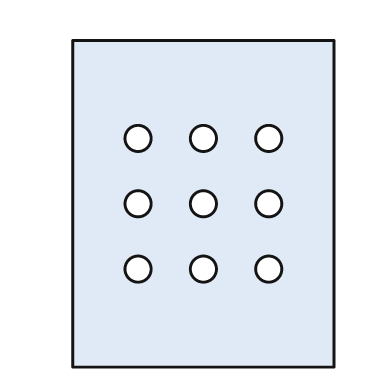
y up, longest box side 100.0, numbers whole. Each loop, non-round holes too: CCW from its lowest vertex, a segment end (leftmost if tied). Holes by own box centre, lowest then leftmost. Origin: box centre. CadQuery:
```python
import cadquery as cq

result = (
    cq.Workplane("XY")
    .moveTo(-40.0, -50.0)
    .lineTo(40.0, -50.0)
    .lineTo(40.0, 50.0)
    .lineTo(-40.0, 50.0)
    .close()
    .moveTo(-20.0, -20.0)
    .circle(4.0)
    .moveTo(0.0, -20.0)
    .circle(4.0)
    .moveTo(20.0, -20.0)
    .circle(4.0)
    .moveTo(-20.0, 0.0)
    .circle(4.0)
    .moveTo(0.0, 0.0)
    .circle(4.0)
    .moveTo(20.0, 0.0)
    .circle(4.0)
    .moveTo(-20.0, 20.0)
    .circle(4.0)
    .moveTo(0.0, 20.0)
    .circle(4.0)
    .moveTo(20.0, 20.0)
    .circle(4.0)
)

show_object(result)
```